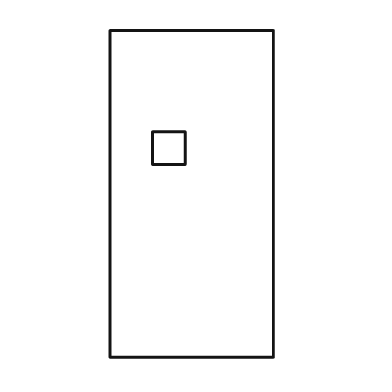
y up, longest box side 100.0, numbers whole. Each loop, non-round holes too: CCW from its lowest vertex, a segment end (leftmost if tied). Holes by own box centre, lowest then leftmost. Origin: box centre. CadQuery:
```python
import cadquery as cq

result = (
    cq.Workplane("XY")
    .moveTo(-25.0, -50.0)
    .lineTo(25.0, -50.0)
    .lineTo(25.0, 50.0)
    .lineTo(-25.0, 50.0)
    .close()
    .moveTo(-12.0, 9.0)
    .lineTo(-2.0, 9.0)
    .lineTo(-2.0, 19.0)
    .lineTo(-12.0, 19.0)
    .close()
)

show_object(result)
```